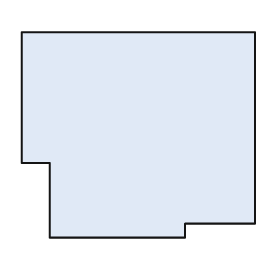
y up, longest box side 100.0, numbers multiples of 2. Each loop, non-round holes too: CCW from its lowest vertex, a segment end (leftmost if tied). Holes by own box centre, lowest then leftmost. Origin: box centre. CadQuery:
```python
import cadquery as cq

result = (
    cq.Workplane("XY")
    .moveTo(-38.0, -44.0)
    .lineTo(20.0, -44.0)
    .lineTo(20.0, -38.0)
    .lineTo(50.0, -38.0)
    .lineTo(50.0, 44.0)
    .lineTo(-50.0, 44.0)
    .lineTo(-50.0, -12.0)
    .lineTo(-38.0, -12.0)
    .close()
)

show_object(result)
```